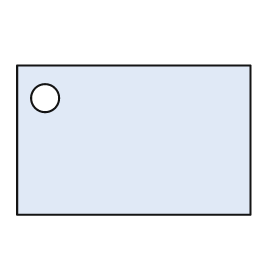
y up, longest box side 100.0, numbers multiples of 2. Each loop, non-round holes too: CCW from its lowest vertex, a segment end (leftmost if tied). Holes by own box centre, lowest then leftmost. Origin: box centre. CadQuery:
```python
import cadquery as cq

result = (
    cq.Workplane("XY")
    .moveTo(-50.0, -32.0)
    .lineTo(50.0, -32.0)
    .lineTo(50.0, 32.0)
    .lineTo(-50.0, 32.0)
    .close()
    .moveTo(-38.0, 18.0)
    .circle(6.0)
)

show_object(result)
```